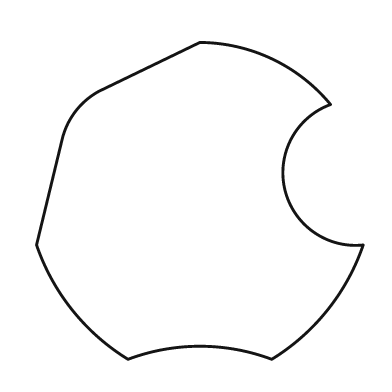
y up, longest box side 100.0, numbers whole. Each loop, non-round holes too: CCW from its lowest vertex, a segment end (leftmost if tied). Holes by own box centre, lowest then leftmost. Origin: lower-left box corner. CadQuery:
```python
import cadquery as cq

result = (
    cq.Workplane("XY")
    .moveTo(28.0, 0.0)
    .threePointArc((50.0, 4.0), (72.0, 0.0))
    .threePointArc((89.0, 15.0), (100.0, 35.0))
    .threePointArc((76.0, 52.0), (90.0, 78.0))
    .threePointArc((72.0, 92.0), (50.0, 97.0))
    .lineTo(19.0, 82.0)
    .threePointArc((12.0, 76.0), (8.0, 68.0))
    .lineTo(0.0, 35.0)
    .threePointArc((11.0, 15.0), (28.0, 0.0))
    .close()
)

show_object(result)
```